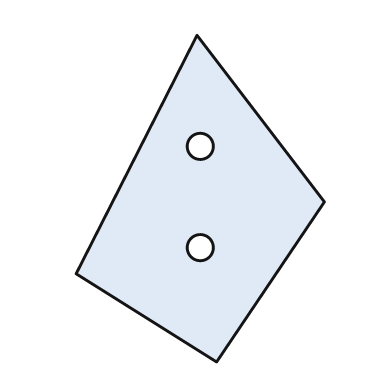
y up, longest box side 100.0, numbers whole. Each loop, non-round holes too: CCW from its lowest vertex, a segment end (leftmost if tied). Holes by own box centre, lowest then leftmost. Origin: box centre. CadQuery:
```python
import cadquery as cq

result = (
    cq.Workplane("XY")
    .moveTo(5.0, -50.0)
    .lineTo(38.0, -1.0)
    .lineTo(-1.0, 50.0)
    .lineTo(-38.0, -23.0)
    .close()
    .moveTo(0.0, -15.0)
    .circle(4.0)
    .moveTo(0.0, 16.0)
    .circle(4.0)
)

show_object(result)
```